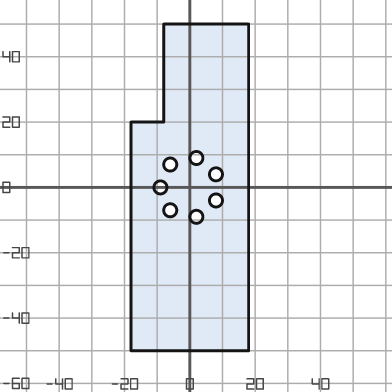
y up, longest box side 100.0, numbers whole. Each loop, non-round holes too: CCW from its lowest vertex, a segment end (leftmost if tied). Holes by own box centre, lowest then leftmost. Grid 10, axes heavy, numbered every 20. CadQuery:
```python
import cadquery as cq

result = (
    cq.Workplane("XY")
    .moveTo(-18.0, -50.0)
    .lineTo(18.0, -50.0)
    .lineTo(18.0, 50.0)
    .lineTo(-8.0, 50.0)
    .lineTo(-8.0, 20.0)
    .lineTo(-18.0, 20.0)
    .close()
    .moveTo(2.0, -9.0)
    .circle(2.0)
    .moveTo(-6.0, -7.0)
    .circle(2.0)
    .moveTo(8.0, -4.0)
    .circle(2.0)
    .moveTo(-9.0, 0.0)
    .circle(2.0)
    .moveTo(8.0, 4.0)
    .circle(2.0)
    .moveTo(-6.0, 7.0)
    .circle(2.0)
    .moveTo(2.0, 9.0)
    .circle(2.0)
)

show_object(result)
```